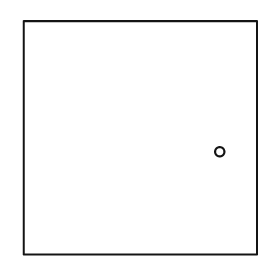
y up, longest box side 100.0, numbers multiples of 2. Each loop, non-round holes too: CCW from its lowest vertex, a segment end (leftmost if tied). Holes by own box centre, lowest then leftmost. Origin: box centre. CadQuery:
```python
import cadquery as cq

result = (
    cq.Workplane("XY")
    .moveTo(-50.0, -50.0)
    .lineTo(50.0, -50.0)
    .lineTo(50.0, 50.0)
    .lineTo(-50.0, 50.0)
    .close()
    .moveTo(34.0, -6.0)
    .circle(2.0)
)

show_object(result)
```